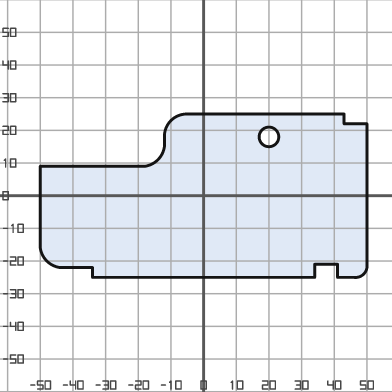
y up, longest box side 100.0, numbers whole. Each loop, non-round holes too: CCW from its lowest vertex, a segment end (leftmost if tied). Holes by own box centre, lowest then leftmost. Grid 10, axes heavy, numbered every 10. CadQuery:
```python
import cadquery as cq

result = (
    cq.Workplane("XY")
    .moveTo(-34.0, -25.0)
    .lineTo(34.0, -25.0)
    .lineTo(34.0, -21.0)
    .lineTo(41.0, -21.0)
    .lineTo(41.0, -25.0)
    .lineTo(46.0, -25.0)
    .threePointArc((49.0, -24.0), (50.0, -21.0))
    .lineTo(50.0, 22.0)
    .lineTo(43.0, 22.0)
    .lineTo(43.0, 25.0)
    .lineTo(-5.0, 25.0)
    .threePointArc((-10.0, 23.0), (-12.0, 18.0))
    .lineTo(-12.0, 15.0)
    .threePointArc((-14.0, 11.0), (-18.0, 9.0))
    .lineTo(-50.0, 9.0)
    .lineTo(-50.0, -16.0)
    .threePointArc((-48.0, -20.0), (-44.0, -22.0))
    .lineTo(-34.0, -22.0)
    .close()
    .moveTo(20.0, 18.0)
    .circle(3.0)
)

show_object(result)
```